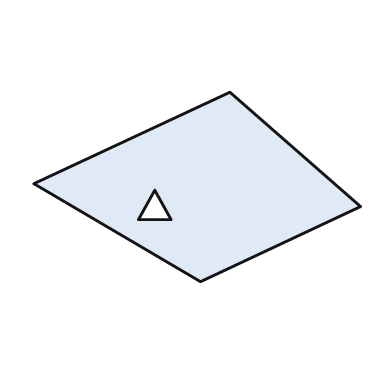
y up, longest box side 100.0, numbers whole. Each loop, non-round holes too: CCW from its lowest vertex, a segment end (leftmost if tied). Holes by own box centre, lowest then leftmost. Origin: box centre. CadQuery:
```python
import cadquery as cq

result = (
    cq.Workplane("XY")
    .moveTo(1.0, -29.0)
    .lineTo(50.0, -6.0)
    .lineTo(10.0, 29.0)
    .lineTo(-50.0, 1.0)
    .close()
    .moveTo(-18.0, -10.0)
    .lineTo(-8.0, -10.0)
    .lineTo(-13.0, -1.0)
    .close()
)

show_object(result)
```